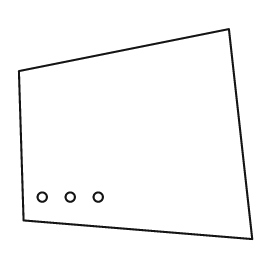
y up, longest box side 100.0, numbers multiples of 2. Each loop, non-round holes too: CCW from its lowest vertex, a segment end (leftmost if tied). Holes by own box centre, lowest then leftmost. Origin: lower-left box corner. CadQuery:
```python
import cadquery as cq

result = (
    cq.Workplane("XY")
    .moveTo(100.0, 0.0)
    .lineTo(90.0, 90.0)
    .lineTo(0.0, 72.0)
    .lineTo(2.0, 8.0)
    .close()
    .moveTo(10.0, 18.0)
    .circle(2.0)
    .moveTo(22.0, 18.0)
    .circle(2.0)
    .moveTo(34.0, 18.0)
    .circle(2.0)
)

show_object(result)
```